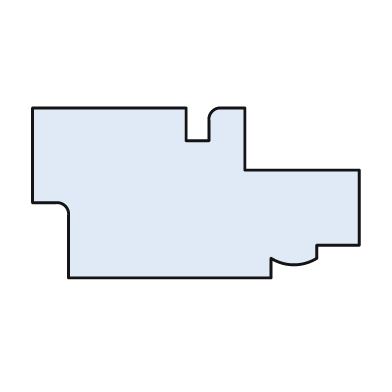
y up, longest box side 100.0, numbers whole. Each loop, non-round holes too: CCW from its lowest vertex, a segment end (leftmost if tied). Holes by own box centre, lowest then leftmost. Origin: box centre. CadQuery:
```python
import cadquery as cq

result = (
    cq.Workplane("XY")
    .moveTo(-39.0, -26.0)
    .lineTo(23.0, -26.0)
    .lineTo(23.0, -20.0)
    .threePointArc((30.0, -22.0), (37.0, -20.0))
    .lineTo(37.0, -16.0)
    .lineTo(50.0, -16.0)
    .lineTo(50.0, 7.0)
    .lineTo(15.0, 7.0)
    .lineTo(15.0, 26.0)
    .lineTo(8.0, 26.0)
    .threePointArc((5.0, 25.0), (4.0, 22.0))
    .lineTo(4.0, 16.0)
    .lineTo(-3.0, 16.0)
    .lineTo(-3.0, 26.0)
    .lineTo(-50.0, 26.0)
    .lineTo(-50.0, -3.0)
    .lineTo(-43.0, -3.0)
    .threePointArc((-40.0, -4.0), (-39.0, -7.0))
    .close()
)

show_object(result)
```